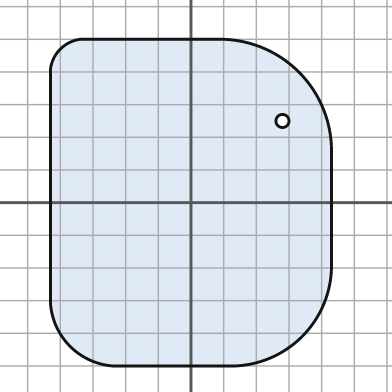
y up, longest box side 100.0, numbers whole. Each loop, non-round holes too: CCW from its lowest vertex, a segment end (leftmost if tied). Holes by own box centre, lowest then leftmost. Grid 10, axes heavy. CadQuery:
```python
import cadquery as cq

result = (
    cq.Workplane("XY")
    .moveTo(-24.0, -50.0)
    .lineTo(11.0, -50.0)
    .threePointArc((34.0, -41.0), (43.0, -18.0))
    .lineTo(43.0, 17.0)
    .threePointArc((33.0, 40.0), (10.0, 50.0))
    .lineTo(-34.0, 50.0)
    .threePointArc((-40.0, 47.0), (-43.0, 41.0))
    .lineTo(-43.0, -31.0)
    .threePointArc((-37.0, -44.0), (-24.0, -50.0))
    .close()
    .moveTo(28.0, 25.0)
    .circle(2.0)
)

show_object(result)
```